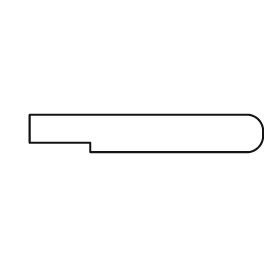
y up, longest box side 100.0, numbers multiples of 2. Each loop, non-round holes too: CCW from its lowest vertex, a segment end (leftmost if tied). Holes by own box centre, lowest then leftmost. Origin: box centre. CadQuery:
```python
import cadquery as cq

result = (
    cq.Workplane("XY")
    .moveTo(-24.0, -8.0)
    .lineTo(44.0, -8.0)
    .threePointArc((48.0, -6.0), (50.0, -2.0))
    .lineTo(50.0, 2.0)
    .threePointArc((48.0, 6.0), (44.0, 8.0))
    .lineTo(-50.0, 8.0)
    .lineTo(-50.0, -4.0)
    .lineTo(-24.0, -4.0)
    .close()
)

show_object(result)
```